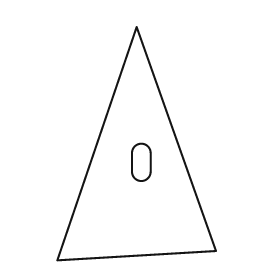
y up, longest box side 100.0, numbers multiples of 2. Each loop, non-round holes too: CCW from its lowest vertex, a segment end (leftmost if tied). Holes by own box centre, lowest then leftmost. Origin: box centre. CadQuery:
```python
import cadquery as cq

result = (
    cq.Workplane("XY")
    .moveTo(-34.0, -50.0)
    .lineTo(34.0, -46.0)
    .lineTo(0.0, 50.0)
    .close()
    .moveTo(-2.0, -12.0)
    .threePointArc((2.0, -16.0), (6.0, -12.0))
    .lineTo(6.0, -4.0)
    .threePointArc((2.0, 0.0), (-2.0, -4.0))
    .close()
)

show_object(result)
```